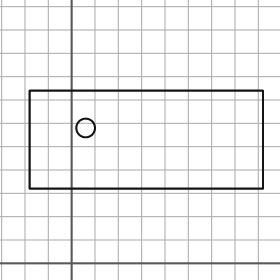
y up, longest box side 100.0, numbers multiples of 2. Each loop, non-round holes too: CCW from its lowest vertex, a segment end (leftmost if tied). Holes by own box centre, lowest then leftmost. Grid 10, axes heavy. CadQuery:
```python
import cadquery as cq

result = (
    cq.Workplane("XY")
    .moveTo(-18.0, 32.0)
    .lineTo(82.0, 32.0)
    .lineTo(82.0, 74.0)
    .lineTo(-18.0, 74.0)
    .close()
    .moveTo(6.0, 58.0)
    .circle(4.0)
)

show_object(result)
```